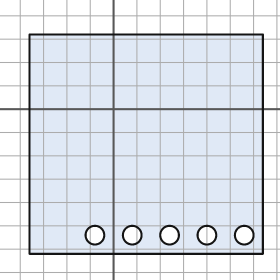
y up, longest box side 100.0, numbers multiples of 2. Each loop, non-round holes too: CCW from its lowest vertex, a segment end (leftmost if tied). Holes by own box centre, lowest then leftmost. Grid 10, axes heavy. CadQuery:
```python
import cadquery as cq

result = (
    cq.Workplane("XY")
    .moveTo(-36.0, -62.0)
    .lineTo(64.0, -62.0)
    .lineTo(64.0, 32.0)
    .lineTo(-36.0, 32.0)
    .close()
    .moveTo(-8.0, -54.0)
    .circle(4.0)
    .moveTo(8.0, -54.0)
    .circle(4.0)
    .moveTo(24.0, -54.0)
    .circle(4.0)
    .moveTo(40.0, -54.0)
    .circle(4.0)
    .moveTo(56.0, -54.0)
    .circle(4.0)
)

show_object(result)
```